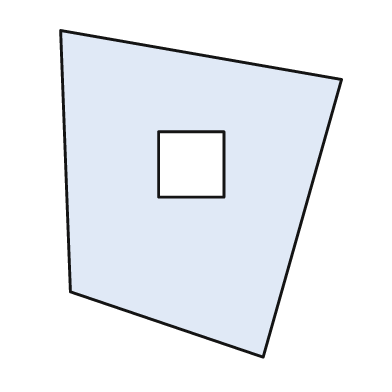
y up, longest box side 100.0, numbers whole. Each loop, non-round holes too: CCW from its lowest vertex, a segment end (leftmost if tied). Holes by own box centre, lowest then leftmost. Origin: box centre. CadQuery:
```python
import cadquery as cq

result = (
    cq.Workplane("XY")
    .moveTo(19.0, -50.0)
    .lineTo(43.0, 35.0)
    .lineTo(-43.0, 50.0)
    .lineTo(-40.0, -30.0)
    .close()
    .moveTo(-13.0, -1.0)
    .lineTo(7.0, -1.0)
    .lineTo(7.0, 19.0)
    .lineTo(-13.0, 19.0)
    .close()
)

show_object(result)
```